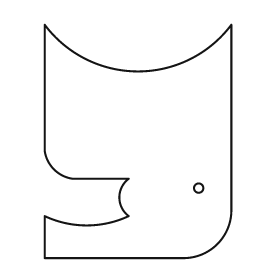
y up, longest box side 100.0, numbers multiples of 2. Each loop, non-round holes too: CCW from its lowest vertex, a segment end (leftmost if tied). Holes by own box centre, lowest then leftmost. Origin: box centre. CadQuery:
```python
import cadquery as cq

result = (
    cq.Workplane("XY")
    .moveTo(-40.0, -50.0)
    .lineTo(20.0, -50.0)
    .threePointArc((34.0, -44.0), (40.0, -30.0))
    .lineTo(40.0, 50.0)
    .threePointArc((0.0, 30.0), (-40.0, 50.0))
    .lineTo(-40.0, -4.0)
    .threePointArc((-36.0, -12.0), (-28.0, -16.0))
    .lineTo(-4.0, -16.0)
    .threePointArc((-8.0, -24.0), (-4.0, -32.0))
    .threePointArc((-22.0, -36.0), (-40.0, -32.0))
    .close()
    .moveTo(26.0, -20.0)
    .circle(2.0)
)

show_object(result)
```